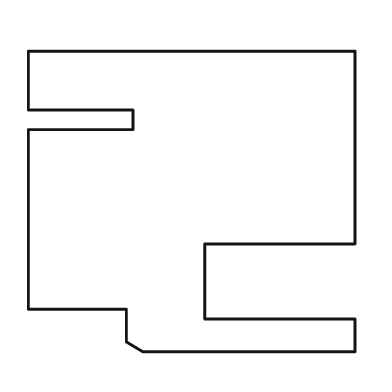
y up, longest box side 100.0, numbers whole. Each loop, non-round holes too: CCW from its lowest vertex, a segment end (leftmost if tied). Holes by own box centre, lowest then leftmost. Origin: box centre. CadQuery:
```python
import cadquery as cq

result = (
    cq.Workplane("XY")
    .moveTo(-15.0, -46.0)
    .lineTo(50.0, -46.0)
    .lineTo(50.0, -36.0)
    .lineTo(4.0, -36.0)
    .lineTo(4.0, -13.0)
    .lineTo(50.0, -13.0)
    .lineTo(50.0, 46.0)
    .lineTo(-50.0, 46.0)
    .lineTo(-50.0, 28.0)
    .lineTo(-18.0, 28.0)
    .lineTo(-18.0, 22.0)
    .lineTo(-50.0, 22.0)
    .lineTo(-50.0, -33.0)
    .lineTo(-20.0, -33.0)
    .lineTo(-20.0, -43.0)
    .close()
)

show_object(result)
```